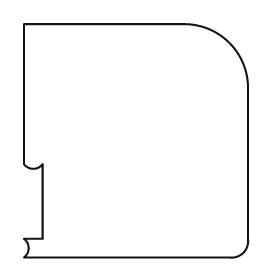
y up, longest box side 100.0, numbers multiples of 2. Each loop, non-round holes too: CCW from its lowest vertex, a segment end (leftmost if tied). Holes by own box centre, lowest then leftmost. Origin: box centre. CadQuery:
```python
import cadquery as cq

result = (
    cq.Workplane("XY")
    .moveTo(-48.0, -50.0)
    .lineTo(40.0, -50.0)
    .threePointArc((46.0, -48.0), (48.0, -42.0))
    .lineTo(48.0, 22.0)
    .threePointArc((40.0, 42.0), (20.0, 50.0))
    .lineTo(-48.0, 50.0)
    .lineTo(-48.0, -10.0)
    .threePointArc((-44.0, -12.0), (-40.0, -10.0))
    .lineTo(-40.0, -42.0)
    .lineTo(-48.0, -42.0)
    .threePointArc((-46.0, -46.0), (-48.0, -50.0))
    .close()
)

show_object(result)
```